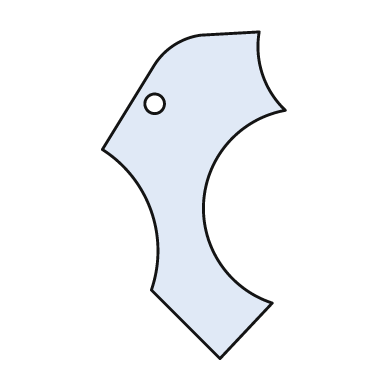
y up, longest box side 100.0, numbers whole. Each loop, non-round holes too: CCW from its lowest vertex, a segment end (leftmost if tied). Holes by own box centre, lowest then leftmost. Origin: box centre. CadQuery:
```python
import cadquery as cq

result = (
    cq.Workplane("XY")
    .moveTo(8.0, -50.0)
    .lineTo(24.0, -33.0)
    .threePointArc((3.0, -2.0), (28.0, 26.0))
    .threePointArc((21.0, 37.0), (20.0, 50.0))
    .lineTo(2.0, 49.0)
    .threePointArc((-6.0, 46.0), (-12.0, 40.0))
    .lineTo(-28.0, 14.0)
    .threePointArc((-13.0, -5.0), (-13.0, -29.0))
    .close()
    .moveTo(-12.0, 28.0)
    .circle(3.0)
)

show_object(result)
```